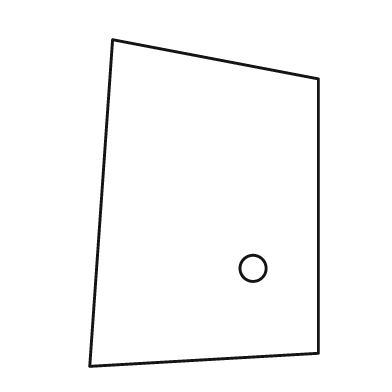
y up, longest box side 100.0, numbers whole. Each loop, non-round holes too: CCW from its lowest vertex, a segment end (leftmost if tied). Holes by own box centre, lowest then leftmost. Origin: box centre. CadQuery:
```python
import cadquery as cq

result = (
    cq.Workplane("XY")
    .moveTo(-35.0, -50.0)
    .lineTo(35.0, -46.0)
    .lineTo(35.0, 38.0)
    .lineTo(-28.0, 50.0)
    .close()
    .moveTo(15.0, -20.0)
    .circle(4.0)
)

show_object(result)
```